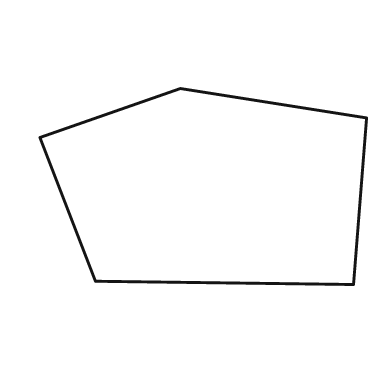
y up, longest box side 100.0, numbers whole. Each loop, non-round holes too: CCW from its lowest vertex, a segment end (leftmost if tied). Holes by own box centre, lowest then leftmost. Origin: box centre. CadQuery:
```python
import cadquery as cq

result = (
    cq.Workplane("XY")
    .moveTo(46.0, -30.0)
    .lineTo(50.0, 21.0)
    .lineTo(-7.0, 30.0)
    .lineTo(-50.0, 15.0)
    .lineTo(-33.0, -29.0)
    .close()
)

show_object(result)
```